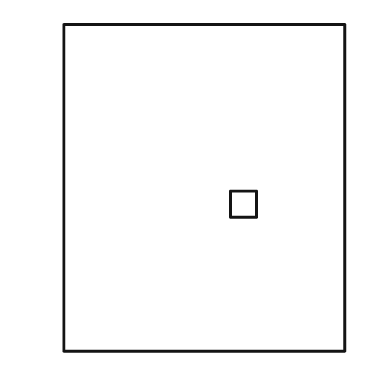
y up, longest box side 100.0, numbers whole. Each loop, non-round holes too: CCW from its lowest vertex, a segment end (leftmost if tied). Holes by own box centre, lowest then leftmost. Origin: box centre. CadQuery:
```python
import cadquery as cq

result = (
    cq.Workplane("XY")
    .moveTo(-43.0, -50.0)
    .lineTo(43.0, -50.0)
    .lineTo(43.0, 50.0)
    .lineTo(-43.0, 50.0)
    .close()
    .moveTo(8.0, -9.0)
    .lineTo(16.0, -9.0)
    .lineTo(16.0, -1.0)
    .lineTo(8.0, -1.0)
    .close()
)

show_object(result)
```